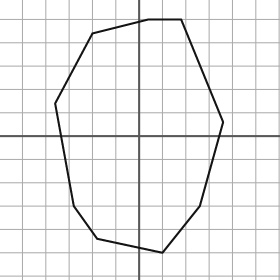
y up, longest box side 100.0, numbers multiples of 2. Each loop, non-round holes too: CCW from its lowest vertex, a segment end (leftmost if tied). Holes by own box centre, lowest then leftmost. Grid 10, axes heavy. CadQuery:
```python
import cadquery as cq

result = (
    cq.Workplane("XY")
    .moveTo(10.0, -50.0)
    .lineTo(26.0, -30.0)
    .lineTo(36.0, 6.0)
    .lineTo(18.0, 50.0)
    .lineTo(4.0, 50.0)
    .lineTo(-20.0, 44.0)
    .lineTo(-36.0, 14.0)
    .lineTo(-28.0, -30.0)
    .lineTo(-18.0, -44.0)
    .close()
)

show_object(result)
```